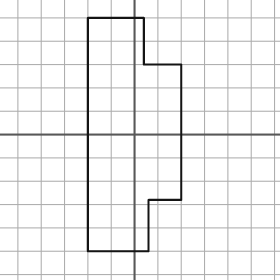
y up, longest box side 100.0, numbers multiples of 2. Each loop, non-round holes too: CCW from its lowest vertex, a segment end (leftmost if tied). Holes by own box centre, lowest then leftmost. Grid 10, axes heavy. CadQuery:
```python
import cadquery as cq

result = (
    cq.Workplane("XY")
    .moveTo(-20.0, -50.0)
    .lineTo(6.0, -50.0)
    .lineTo(6.0, -28.0)
    .lineTo(20.0, -28.0)
    .lineTo(20.0, 30.0)
    .lineTo(4.0, 30.0)
    .lineTo(4.0, 50.0)
    .lineTo(-20.0, 50.0)
    .close()
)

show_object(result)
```